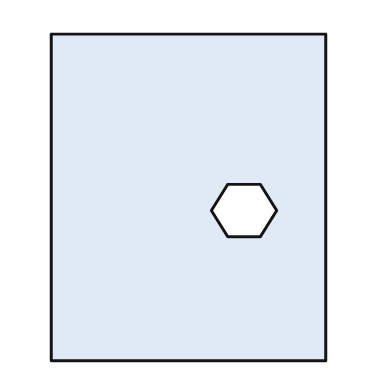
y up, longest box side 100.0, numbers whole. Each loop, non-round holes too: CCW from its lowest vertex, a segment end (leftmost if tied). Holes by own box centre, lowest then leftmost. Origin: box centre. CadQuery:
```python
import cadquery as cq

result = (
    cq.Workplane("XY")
    .moveTo(-42.0, -50.0)
    .lineTo(42.0, -50.0)
    .lineTo(42.0, 50.0)
    .lineTo(-42.0, 50.0)
    .close()
    .moveTo(12.0, -12.0)
    .lineTo(22.0, -12.0)
    .lineTo(27.0, -4.0)
    .lineTo(22.0, 4.0)
    .lineTo(12.0, 4.0)
    .lineTo(7.0, -4.0)
    .close()
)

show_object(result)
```